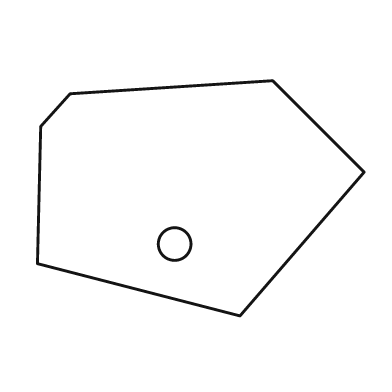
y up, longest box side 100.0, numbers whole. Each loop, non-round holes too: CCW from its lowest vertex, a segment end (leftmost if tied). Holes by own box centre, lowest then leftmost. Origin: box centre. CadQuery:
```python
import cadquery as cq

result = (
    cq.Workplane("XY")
    .moveTo(12.0, -36.0)
    .lineTo(50.0, 8.0)
    .lineTo(22.0, 36.0)
    .lineTo(-40.0, 32.0)
    .lineTo(-49.0, 22.0)
    .lineTo(-50.0, -20.0)
    .close()
    .moveTo(-8.0, -14.0)
    .circle(5.0)
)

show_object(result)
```